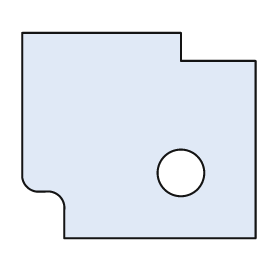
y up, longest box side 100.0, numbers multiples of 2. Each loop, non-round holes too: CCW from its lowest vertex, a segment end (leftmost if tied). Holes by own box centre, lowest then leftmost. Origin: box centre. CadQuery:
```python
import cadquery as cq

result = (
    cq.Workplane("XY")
    .moveTo(-32.0, -44.0)
    .lineTo(50.0, -44.0)
    .lineTo(50.0, 32.0)
    .lineTo(18.0, 32.0)
    .lineTo(18.0, 44.0)
    .lineTo(-50.0, 44.0)
    .lineTo(-50.0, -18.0)
    .threePointArc((-48.0, -22.0), (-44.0, -24.0))
    .lineTo(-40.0, -24.0)
    .threePointArc((-34.0, -26.0), (-32.0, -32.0))
    .close()
    .moveTo(18.0, -16.0)
    .circle(10.0)
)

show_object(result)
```